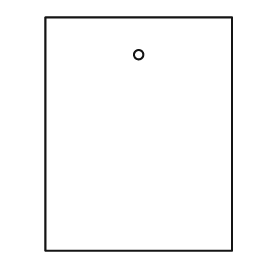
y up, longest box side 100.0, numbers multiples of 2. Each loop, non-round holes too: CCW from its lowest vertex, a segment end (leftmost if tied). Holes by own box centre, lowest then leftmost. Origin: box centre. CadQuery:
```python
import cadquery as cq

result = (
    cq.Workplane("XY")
    .moveTo(-40.0, -50.0)
    .lineTo(40.0, -50.0)
    .lineTo(40.0, 50.0)
    .lineTo(-40.0, 50.0)
    .close()
    .moveTo(0.0, 34.0)
    .circle(2.0)
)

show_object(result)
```